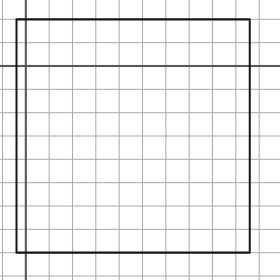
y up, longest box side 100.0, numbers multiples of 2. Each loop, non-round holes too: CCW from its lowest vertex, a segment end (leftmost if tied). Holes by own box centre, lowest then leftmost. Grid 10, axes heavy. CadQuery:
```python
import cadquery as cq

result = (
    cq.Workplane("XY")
    .moveTo(-4.0, -80.0)
    .lineTo(96.0, -80.0)
    .lineTo(96.0, 20.0)
    .lineTo(-4.0, 20.0)
    .close()
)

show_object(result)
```